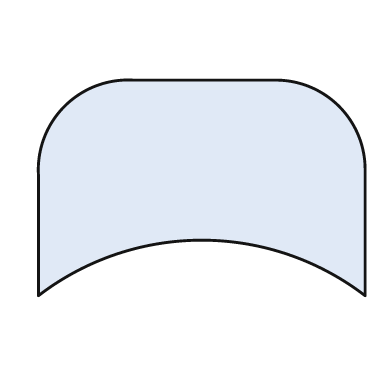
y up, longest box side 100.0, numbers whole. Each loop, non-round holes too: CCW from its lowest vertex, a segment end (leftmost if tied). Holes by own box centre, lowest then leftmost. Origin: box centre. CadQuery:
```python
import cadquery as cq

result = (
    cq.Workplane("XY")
    .moveTo(-50.0, -33.0)
    .threePointArc((0.0, -16.0), (50.0, -33.0))
    .lineTo(50.0, 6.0)
    .threePointArc((42.0, 25.0), (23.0, 33.0))
    .lineTo(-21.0, 33.0)
    .threePointArc((-42.0, 25.0), (-50.0, 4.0))
    .close()
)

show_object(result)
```